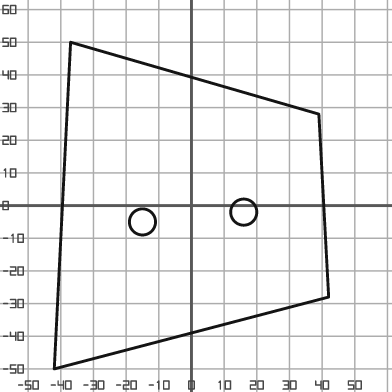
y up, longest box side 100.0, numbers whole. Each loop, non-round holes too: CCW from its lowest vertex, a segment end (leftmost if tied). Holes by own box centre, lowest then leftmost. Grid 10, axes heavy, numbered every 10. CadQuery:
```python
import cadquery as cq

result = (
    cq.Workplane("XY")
    .moveTo(-42.0, -50.0)
    .lineTo(42.0, -28.0)
    .lineTo(39.0, 28.0)
    .lineTo(-37.0, 50.0)
    .close()
    .moveTo(-15.0, -5.0)
    .circle(4.0)
    .moveTo(16.0, -2.0)
    .circle(4.0)
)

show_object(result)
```